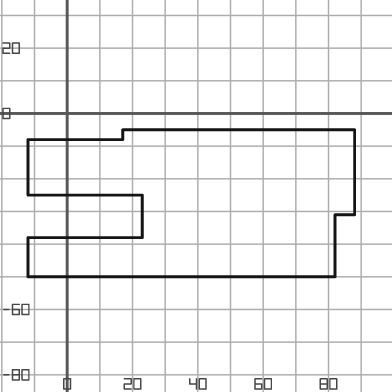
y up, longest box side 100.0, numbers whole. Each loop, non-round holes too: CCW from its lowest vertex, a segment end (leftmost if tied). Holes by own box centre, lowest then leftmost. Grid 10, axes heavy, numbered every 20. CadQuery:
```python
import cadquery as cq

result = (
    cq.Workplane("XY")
    .moveTo(-12.0, -50.0)
    .lineTo(82.0, -50.0)
    .lineTo(82.0, -31.0)
    .lineTo(88.0, -31.0)
    .lineTo(88.0, -5.0)
    .lineTo(17.0, -5.0)
    .lineTo(17.0, -8.0)
    .lineTo(-12.0, -8.0)
    .lineTo(-12.0, -25.0)
    .lineTo(23.0, -25.0)
    .lineTo(23.0, -38.0)
    .lineTo(-12.0, -38.0)
    .close()
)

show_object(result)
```